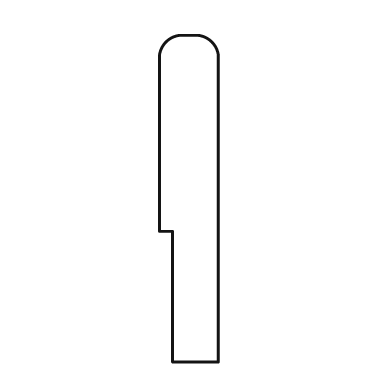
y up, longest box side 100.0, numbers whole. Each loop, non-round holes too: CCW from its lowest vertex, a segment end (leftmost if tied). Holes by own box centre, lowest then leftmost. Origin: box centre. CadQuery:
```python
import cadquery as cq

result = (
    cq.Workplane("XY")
    .moveTo(-5.0, -50.0)
    .lineTo(9.0, -50.0)
    .lineTo(9.0, 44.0)
    .threePointArc((7.0, 48.0), (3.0, 50.0))
    .lineTo(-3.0, 50.0)
    .threePointArc((-7.0, 48.0), (-9.0, 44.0))
    .lineTo(-9.0, -10.0)
    .lineTo(-5.0, -10.0)
    .close()
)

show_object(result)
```